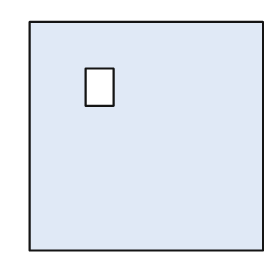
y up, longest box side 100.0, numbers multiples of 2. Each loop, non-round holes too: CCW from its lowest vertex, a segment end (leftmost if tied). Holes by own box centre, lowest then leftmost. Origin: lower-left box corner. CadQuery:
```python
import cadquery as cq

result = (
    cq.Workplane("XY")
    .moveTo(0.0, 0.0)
    .lineTo(100.0, 0.0)
    .lineTo(100.0, 98.0)
    .lineTo(0.0, 98.0)
    .close()
    .moveTo(24.0, 62.0)
    .lineTo(36.0, 62.0)
    .lineTo(36.0, 78.0)
    .lineTo(24.0, 78.0)
    .close()
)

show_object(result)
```